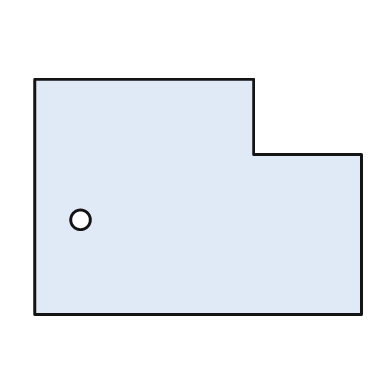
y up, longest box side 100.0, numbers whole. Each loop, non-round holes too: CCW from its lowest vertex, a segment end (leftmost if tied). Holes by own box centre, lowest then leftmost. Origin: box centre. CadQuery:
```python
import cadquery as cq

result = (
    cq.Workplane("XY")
    .moveTo(-50.0, -36.0)
    .lineTo(50.0, -36.0)
    .lineTo(50.0, 13.0)
    .lineTo(17.0, 13.0)
    .lineTo(17.0, 36.0)
    .lineTo(-50.0, 36.0)
    .close()
    .moveTo(-36.0, -7.0)
    .circle(3.0)
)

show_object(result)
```